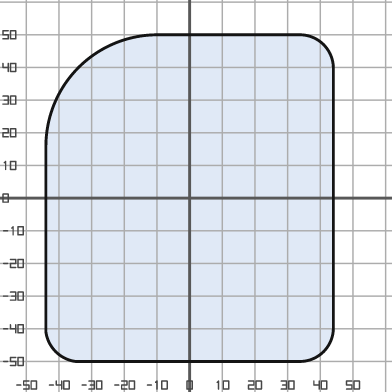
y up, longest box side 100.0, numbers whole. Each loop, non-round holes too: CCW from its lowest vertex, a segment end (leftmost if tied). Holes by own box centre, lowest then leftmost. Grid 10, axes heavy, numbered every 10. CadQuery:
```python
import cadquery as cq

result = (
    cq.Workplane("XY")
    .moveTo(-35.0, -50.0)
    .lineTo(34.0, -50.0)
    .threePointArc((41.0, -47.0), (44.0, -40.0))
    .lineTo(44.0, 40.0)
    .threePointArc((41.0, 47.0), (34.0, 50.0))
    .lineTo(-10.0, 50.0)
    .threePointArc((-34.0, 40.0), (-44.0, 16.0))
    .lineTo(-44.0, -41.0)
    .threePointArc((-41.0, -47.0), (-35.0, -50.0))
    .close()
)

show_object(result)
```